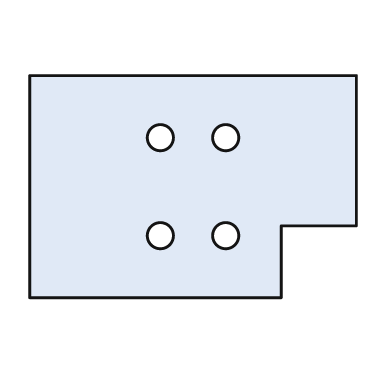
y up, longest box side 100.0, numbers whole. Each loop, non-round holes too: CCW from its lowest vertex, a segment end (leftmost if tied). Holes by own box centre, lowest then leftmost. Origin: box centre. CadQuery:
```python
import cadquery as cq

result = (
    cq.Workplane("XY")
    .moveTo(-50.0, -34.0)
    .lineTo(27.0, -34.0)
    .lineTo(27.0, -12.0)
    .lineTo(50.0, -12.0)
    .lineTo(50.0, 34.0)
    .lineTo(-50.0, 34.0)
    .close()
    .moveTo(-10.0, -15.0)
    .circle(4.0)
    .moveTo(10.0, -15.0)
    .circle(4.0)
    .moveTo(-10.0, 15.0)
    .circle(4.0)
    .moveTo(10.0, 15.0)
    .circle(4.0)
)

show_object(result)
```